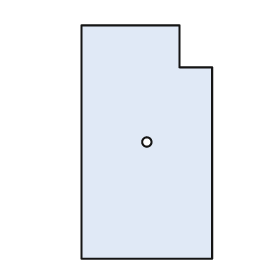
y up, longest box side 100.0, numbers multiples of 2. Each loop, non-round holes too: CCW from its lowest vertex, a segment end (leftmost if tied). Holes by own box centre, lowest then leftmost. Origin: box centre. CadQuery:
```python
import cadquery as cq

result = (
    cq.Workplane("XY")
    .moveTo(-28.0, -50.0)
    .lineTo(28.0, -50.0)
    .lineTo(28.0, 32.0)
    .lineTo(14.0, 32.0)
    .lineTo(14.0, 50.0)
    .lineTo(-28.0, 50.0)
    .close()
    .moveTo(0.0, 0.0)
    .circle(2.0)
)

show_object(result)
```